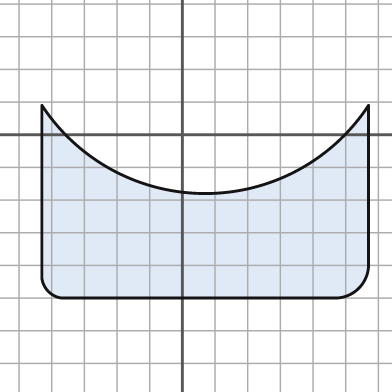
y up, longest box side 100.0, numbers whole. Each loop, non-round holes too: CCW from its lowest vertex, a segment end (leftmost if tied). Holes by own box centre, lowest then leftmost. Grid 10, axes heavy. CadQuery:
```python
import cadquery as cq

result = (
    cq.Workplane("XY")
    .moveTo(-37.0, -50.0)
    .lineTo(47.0, -50.0)
    .threePointArc((54.0, -47.0), (57.0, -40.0))
    .lineTo(57.0, 9.0)
    .threePointArc((7.0, -18.0), (-43.0, 9.0))
    .lineTo(-43.0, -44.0)
    .threePointArc((-41.0, -48.0), (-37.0, -50.0))
    .close()
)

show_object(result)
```